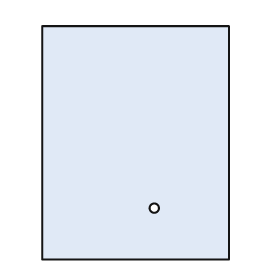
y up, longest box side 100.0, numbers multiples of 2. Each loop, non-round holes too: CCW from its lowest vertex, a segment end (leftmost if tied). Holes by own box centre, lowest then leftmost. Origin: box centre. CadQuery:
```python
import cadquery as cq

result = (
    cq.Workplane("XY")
    .moveTo(-40.0, -50.0)
    .lineTo(40.0, -50.0)
    .lineTo(40.0, 50.0)
    .lineTo(-40.0, 50.0)
    .close()
    .moveTo(8.0, -28.0)
    .circle(2.0)
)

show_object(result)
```